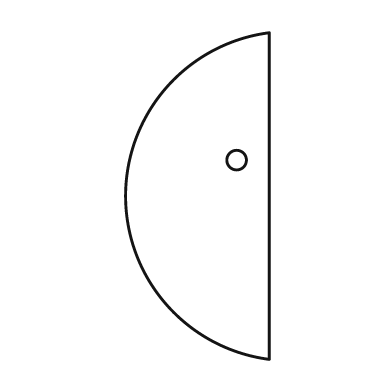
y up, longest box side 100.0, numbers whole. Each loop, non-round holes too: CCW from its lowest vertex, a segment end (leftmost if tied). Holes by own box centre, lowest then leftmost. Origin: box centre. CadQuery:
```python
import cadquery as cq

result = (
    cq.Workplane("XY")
    .moveTo(22.0, -50.0)
    .lineTo(22.0, 50.0)
    .threePointArc((-22.0, 0.0), (22.0, -50.0))
    .close()
    .moveTo(12.0, 11.0)
    .circle(3.0)
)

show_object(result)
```